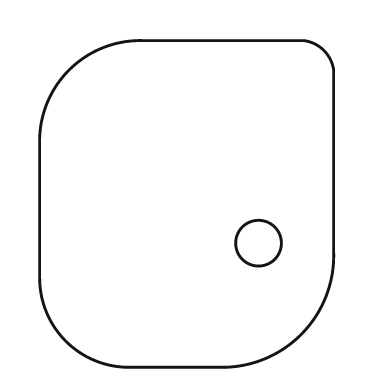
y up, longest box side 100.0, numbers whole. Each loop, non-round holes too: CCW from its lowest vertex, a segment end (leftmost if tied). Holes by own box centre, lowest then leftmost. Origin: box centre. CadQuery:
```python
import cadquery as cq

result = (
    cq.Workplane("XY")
    .moveTo(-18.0, -50.0)
    .lineTo(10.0, -50.0)
    .threePointArc((35.0, -40.0), (45.0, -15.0))
    .lineTo(45.0, 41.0)
    .threePointArc((42.0, 47.0), (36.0, 50.0))
    .lineTo(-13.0, 50.0)
    .threePointArc((-36.0, 41.0), (-45.0, 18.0))
    .lineTo(-45.0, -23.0)
    .threePointArc((-37.0, -42.0), (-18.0, -50.0))
    .close()
    .moveTo(22.0, -12.0)
    .circle(7.0)
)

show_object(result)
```